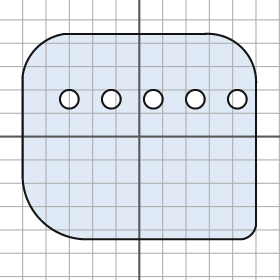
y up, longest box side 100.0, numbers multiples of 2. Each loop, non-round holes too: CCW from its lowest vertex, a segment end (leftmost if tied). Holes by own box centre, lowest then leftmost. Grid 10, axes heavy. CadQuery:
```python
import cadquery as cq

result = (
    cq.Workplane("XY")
    .moveTo(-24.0, -44.0)
    .lineTo(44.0, -44.0)
    .threePointArc((48.0, -42.0), (50.0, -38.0))
    .lineTo(50.0, 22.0)
    .threePointArc((44.0, 38.0), (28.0, 44.0))
    .lineTo(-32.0, 44.0)
    .threePointArc((-44.0, 38.0), (-50.0, 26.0))
    .lineTo(-50.0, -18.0)
    .threePointArc((-42.0, -36.0), (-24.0, -44.0))
    .close()
    .moveTo(-30.0, 16.0)
    .circle(4.0)
    .moveTo(-12.0, 16.0)
    .circle(4.0)
    .moveTo(6.0, 16.0)
    .circle(4.0)
    .moveTo(24.0, 16.0)
    .circle(4.0)
    .moveTo(42.0, 16.0)
    .circle(4.0)
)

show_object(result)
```